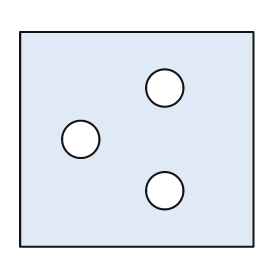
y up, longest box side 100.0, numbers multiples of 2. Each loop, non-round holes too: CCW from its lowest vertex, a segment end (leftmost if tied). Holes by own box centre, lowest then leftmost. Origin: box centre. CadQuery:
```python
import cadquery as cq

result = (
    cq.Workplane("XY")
    .moveTo(-50.0, -46.0)
    .lineTo(50.0, -46.0)
    .lineTo(50.0, 46.0)
    .lineTo(-50.0, 46.0)
    .close()
    .moveTo(12.0, -22.0)
    .circle(8.0)
    .moveTo(-24.0, 0.0)
    .circle(8.0)
    .moveTo(12.0, 22.0)
    .circle(8.0)
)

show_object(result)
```